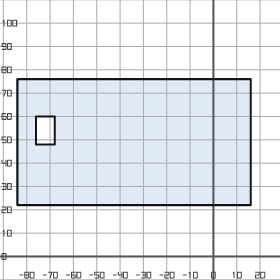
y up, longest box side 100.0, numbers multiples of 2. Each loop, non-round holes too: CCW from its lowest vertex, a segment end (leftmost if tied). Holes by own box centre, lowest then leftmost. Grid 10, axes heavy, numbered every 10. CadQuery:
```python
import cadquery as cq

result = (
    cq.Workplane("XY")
    .moveTo(-84.0, 22.0)
    .lineTo(16.0, 22.0)
    .lineTo(16.0, 76.0)
    .lineTo(-84.0, 76.0)
    .close()
    .moveTo(-76.0, 48.0)
    .lineTo(-68.0, 48.0)
    .lineTo(-68.0, 60.0)
    .lineTo(-76.0, 60.0)
    .close()
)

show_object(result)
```